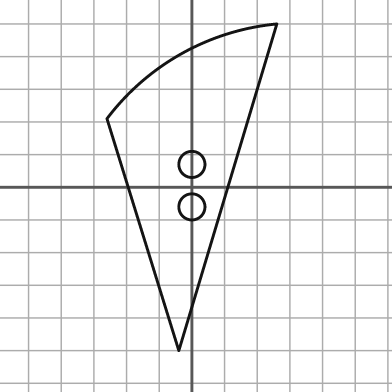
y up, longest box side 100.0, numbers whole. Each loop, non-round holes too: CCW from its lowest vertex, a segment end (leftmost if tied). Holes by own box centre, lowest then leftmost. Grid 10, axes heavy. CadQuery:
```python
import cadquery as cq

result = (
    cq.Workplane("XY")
    .moveTo(-4.0, -50.0)
    .lineTo(26.0, 50.0)
    .threePointArc((-3.0, 41.0), (-26.0, 21.0))
    .close()
    .moveTo(0.0, -6.0)
    .circle(4.0)
    .moveTo(0.0, 7.0)
    .circle(4.0)
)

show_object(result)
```